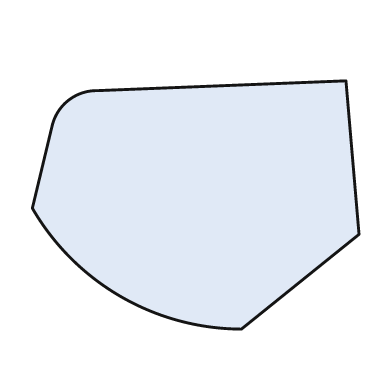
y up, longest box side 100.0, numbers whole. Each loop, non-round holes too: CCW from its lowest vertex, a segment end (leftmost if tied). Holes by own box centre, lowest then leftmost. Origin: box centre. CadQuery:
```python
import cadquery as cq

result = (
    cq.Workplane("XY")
    .moveTo(14.0, -38.0)
    .lineTo(50.0, -9.0)
    .lineTo(46.0, 38.0)
    .lineTo(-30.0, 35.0)
    .threePointArc((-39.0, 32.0), (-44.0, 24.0))
    .lineTo(-50.0, -1.0)
    .threePointArc((-23.0, -28.0), (14.0, -38.0))
    .close()
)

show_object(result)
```